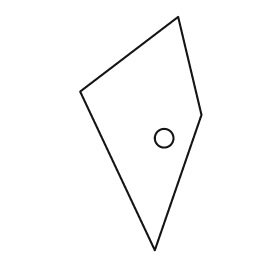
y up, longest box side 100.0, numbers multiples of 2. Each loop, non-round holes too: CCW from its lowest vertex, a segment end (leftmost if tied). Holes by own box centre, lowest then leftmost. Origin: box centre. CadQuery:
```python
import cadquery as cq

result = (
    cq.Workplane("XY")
    .moveTo(6.0, -50.0)
    .lineTo(26.0, 8.0)
    .lineTo(16.0, 50.0)
    .lineTo(-26.0, 18.0)
    .close()
    .moveTo(10.0, -2.0)
    .circle(4.0)
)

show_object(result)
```